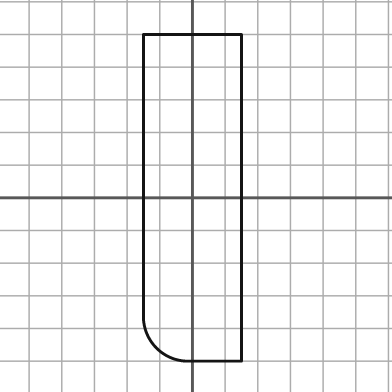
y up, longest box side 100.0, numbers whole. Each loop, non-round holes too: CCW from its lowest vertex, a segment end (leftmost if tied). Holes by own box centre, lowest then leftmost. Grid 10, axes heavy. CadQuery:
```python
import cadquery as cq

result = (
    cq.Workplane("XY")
    .moveTo(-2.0, -50.0)
    .lineTo(15.0, -50.0)
    .lineTo(15.0, 50.0)
    .lineTo(-15.0, 50.0)
    .lineTo(-15.0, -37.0)
    .threePointArc((-11.0, -46.0), (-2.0, -50.0))
    .close()
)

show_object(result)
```